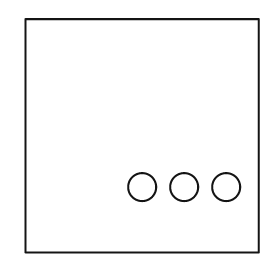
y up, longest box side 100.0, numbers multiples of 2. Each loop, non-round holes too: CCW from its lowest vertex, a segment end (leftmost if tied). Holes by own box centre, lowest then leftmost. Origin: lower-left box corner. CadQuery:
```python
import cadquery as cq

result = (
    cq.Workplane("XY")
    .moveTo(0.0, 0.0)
    .lineTo(100.0, 0.0)
    .lineTo(100.0, 100.0)
    .lineTo(0.0, 100.0)
    .close()
    .moveTo(50.0, 28.0)
    .circle(6.0)
    .moveTo(68.0, 28.0)
    .circle(6.0)
    .moveTo(86.0, 28.0)
    .circle(6.0)
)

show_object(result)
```